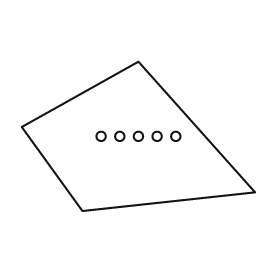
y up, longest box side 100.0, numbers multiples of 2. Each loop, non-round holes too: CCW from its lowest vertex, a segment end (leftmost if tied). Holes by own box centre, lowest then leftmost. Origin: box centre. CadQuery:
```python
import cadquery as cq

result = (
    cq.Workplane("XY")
    .moveTo(-24.0, -32.0)
    .lineTo(50.0, -24.0)
    .lineTo(0.0, 32.0)
    .lineTo(-50.0, 4.0)
    .close()
    .moveTo(-16.0, 0.0)
    .circle(2.0)
    .moveTo(-8.0, 0.0)
    .circle(2.0)
    .moveTo(0.0, 0.0)
    .circle(2.0)
    .moveTo(8.0, 0.0)
    .circle(2.0)
    .moveTo(16.0, 0.0)
    .circle(2.0)
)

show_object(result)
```